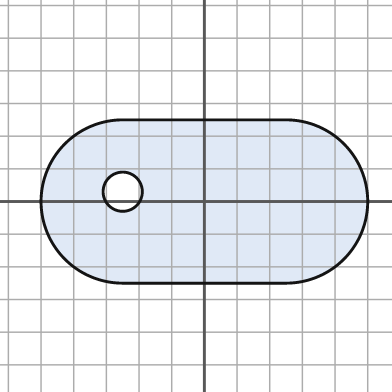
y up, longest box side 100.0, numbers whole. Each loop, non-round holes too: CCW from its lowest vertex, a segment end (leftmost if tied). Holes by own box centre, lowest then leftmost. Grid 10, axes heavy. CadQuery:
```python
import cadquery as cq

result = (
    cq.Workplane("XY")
    .moveTo(-25.0, -25.0)
    .lineTo(25.0, -25.0)
    .threePointArc((50.0, 0.0), (25.0, 25.0))
    .lineTo(-25.0, 25.0)
    .threePointArc((-50.0, 0.0), (-25.0, -25.0))
    .close()
    .moveTo(-25.0, 3.0)
    .circle(6.0)
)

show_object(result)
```